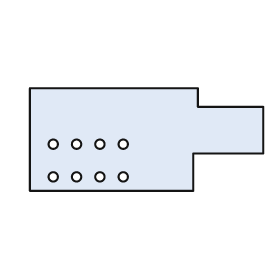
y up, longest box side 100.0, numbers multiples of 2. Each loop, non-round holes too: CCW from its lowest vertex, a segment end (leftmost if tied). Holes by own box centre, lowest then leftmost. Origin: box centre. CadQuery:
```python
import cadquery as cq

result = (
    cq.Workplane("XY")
    .moveTo(-50.0, -22.0)
    .lineTo(20.0, -22.0)
    .lineTo(20.0, -6.0)
    .lineTo(50.0, -6.0)
    .lineTo(50.0, 14.0)
    .lineTo(22.0, 14.0)
    .lineTo(22.0, 22.0)
    .lineTo(-50.0, 22.0)
    .close()
    .moveTo(-40.0, -16.0)
    .circle(2.0)
    .moveTo(-30.0, -16.0)
    .circle(2.0)
    .moveTo(-20.0, -16.0)
    .circle(2.0)
    .moveTo(-10.0, -16.0)
    .circle(2.0)
    .moveTo(-40.0, -2.0)
    .circle(2.0)
    .moveTo(-30.0, -2.0)
    .circle(2.0)
    .moveTo(-20.0, -2.0)
    .circle(2.0)
    .moveTo(-10.0, -2.0)
    .circle(2.0)
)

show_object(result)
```